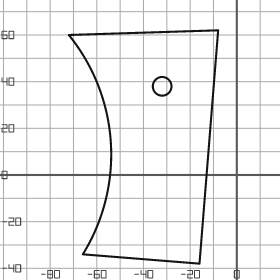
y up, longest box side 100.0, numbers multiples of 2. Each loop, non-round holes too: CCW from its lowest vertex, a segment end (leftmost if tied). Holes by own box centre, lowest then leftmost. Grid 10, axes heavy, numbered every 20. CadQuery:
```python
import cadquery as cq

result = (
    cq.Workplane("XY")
    .moveTo(-16.0, -38.0)
    .lineTo(-8.0, 62.0)
    .lineTo(-72.0, 60.0)
    .threePointArc((-54.0, 14.0), (-66.0, -34.0))
    .close()
    .moveTo(-32.0, 38.0)
    .circle(4.0)
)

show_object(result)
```